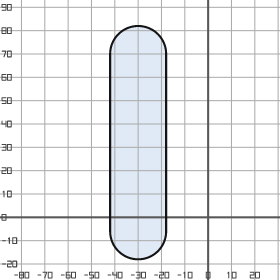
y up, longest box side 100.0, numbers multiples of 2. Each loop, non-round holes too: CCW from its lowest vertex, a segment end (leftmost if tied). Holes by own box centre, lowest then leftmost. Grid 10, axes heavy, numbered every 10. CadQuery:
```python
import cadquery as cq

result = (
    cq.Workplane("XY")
    .moveTo(-42.0, -6.0)
    .threePointArc((-30.0, -18.0), (-18.0, -6.0))
    .lineTo(-18.0, 70.0)
    .threePointArc((-30.0, 82.0), (-42.0, 70.0))
    .close()
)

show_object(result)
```